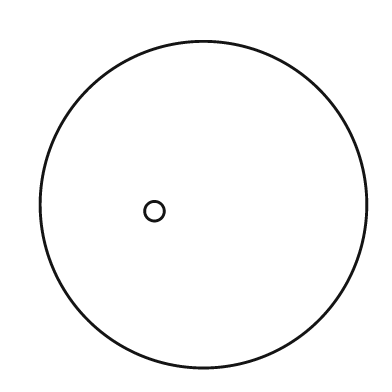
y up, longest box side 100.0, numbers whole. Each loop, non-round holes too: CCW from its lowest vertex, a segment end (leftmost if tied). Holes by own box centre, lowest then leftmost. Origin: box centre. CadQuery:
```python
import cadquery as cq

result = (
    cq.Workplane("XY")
    .moveTo(0.0, 0.0)
    .circle(50.0)
    .moveTo(-15.0, -2.0)
    .circle(3.0)
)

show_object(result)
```